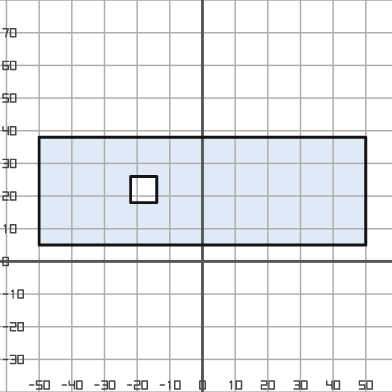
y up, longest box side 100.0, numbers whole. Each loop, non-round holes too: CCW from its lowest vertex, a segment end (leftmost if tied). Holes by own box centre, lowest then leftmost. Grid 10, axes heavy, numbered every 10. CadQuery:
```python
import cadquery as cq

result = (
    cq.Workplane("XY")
    .moveTo(-50.0, 5.0)
    .lineTo(50.0, 5.0)
    .lineTo(50.0, 38.0)
    .lineTo(-50.0, 38.0)
    .close()
    .moveTo(-22.0, 18.0)
    .lineTo(-14.0, 18.0)
    .lineTo(-14.0, 26.0)
    .lineTo(-22.0, 26.0)
    .close()
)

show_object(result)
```